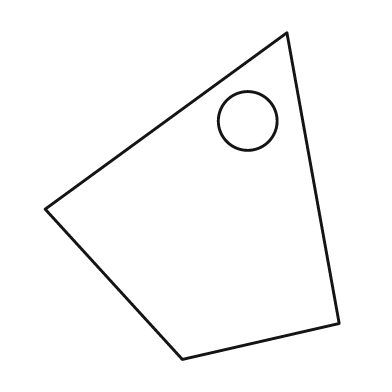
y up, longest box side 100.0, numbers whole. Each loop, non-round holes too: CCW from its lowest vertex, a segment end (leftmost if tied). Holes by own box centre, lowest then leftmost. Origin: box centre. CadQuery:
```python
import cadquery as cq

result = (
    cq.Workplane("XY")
    .moveTo(-3.0, -50.0)
    .lineTo(45.0, -39.0)
    .lineTo(29.0, 50.0)
    .lineTo(-45.0, -4.0)
    .close()
    .moveTo(17.0, 23.0)
    .circle(9.0)
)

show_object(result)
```